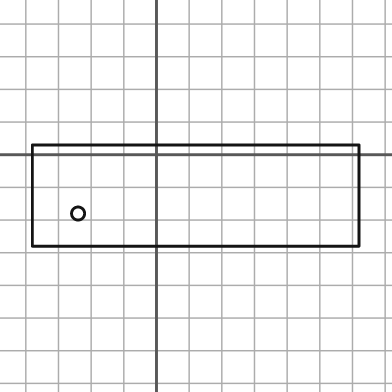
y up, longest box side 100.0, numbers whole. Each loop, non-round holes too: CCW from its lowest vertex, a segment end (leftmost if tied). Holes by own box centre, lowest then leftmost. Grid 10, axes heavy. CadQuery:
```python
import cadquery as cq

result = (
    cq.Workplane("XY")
    .moveTo(-38.0, -28.0)
    .lineTo(62.0, -28.0)
    .lineTo(62.0, 3.0)
    .lineTo(-38.0, 3.0)
    .close()
    .moveTo(-24.0, -18.0)
    .circle(2.0)
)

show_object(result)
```